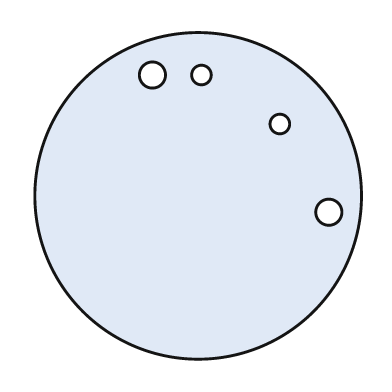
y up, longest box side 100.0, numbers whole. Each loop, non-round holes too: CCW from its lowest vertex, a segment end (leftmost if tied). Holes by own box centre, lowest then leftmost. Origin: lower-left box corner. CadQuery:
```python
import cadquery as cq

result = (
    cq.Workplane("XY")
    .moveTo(50.0, 50.0)
    .circle(50.0)
    .moveTo(90.0, 45.0)
    .circle(4.0)
    .moveTo(75.0, 72.0)
    .circle(3.0)
    .moveTo(36.0, 87.0)
    .circle(4.0)
    .moveTo(51.0, 87.0)
    .circle(3.0)
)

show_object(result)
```